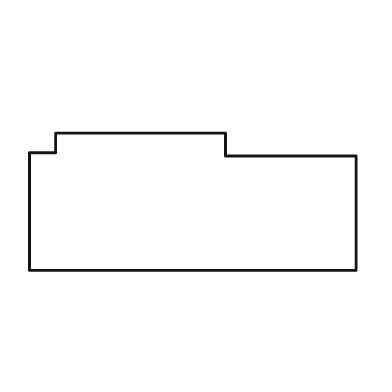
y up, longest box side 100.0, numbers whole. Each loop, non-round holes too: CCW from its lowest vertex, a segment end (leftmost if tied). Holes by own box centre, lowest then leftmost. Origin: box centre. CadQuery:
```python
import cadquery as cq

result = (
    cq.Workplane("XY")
    .moveTo(-50.0, -21.0)
    .lineTo(50.0, -21.0)
    .lineTo(50.0, 14.0)
    .lineTo(10.0, 14.0)
    .lineTo(10.0, 21.0)
    .lineTo(-42.0, 21.0)
    .lineTo(-42.0, 15.0)
    .lineTo(-50.0, 15.0)
    .close()
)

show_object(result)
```